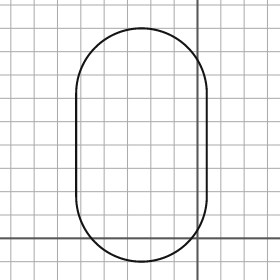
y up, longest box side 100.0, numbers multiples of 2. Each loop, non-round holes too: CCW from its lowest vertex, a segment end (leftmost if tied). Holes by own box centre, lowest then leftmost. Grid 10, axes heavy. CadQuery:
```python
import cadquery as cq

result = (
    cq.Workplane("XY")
    .moveTo(-52.0, 18.0)
    .threePointArc((-24.0, -10.0), (4.0, 18.0))
    .lineTo(4.0, 62.0)
    .threePointArc((-24.0, 90.0), (-52.0, 62.0))
    .close()
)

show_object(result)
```